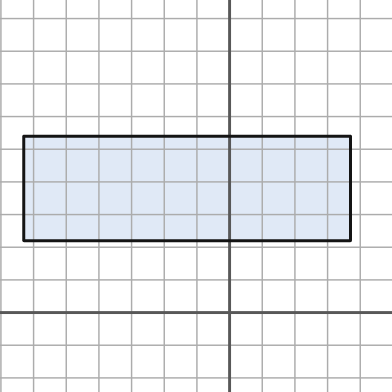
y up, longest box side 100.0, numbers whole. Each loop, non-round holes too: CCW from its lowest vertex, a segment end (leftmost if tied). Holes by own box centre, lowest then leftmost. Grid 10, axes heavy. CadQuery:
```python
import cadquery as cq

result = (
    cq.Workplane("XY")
    .moveTo(-63.0, 22.0)
    .lineTo(37.0, 22.0)
    .lineTo(37.0, 54.0)
    .lineTo(-63.0, 54.0)
    .close()
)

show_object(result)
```